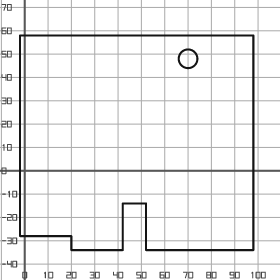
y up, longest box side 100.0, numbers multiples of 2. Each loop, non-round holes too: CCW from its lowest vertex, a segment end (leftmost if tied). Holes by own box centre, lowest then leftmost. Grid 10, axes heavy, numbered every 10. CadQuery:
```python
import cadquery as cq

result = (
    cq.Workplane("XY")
    .moveTo(20.0, -34.0)
    .lineTo(42.0, -34.0)
    .lineTo(42.0, -14.0)
    .lineTo(52.0, -14.0)
    .lineTo(52.0, -34.0)
    .lineTo(98.0, -34.0)
    .lineTo(98.0, 58.0)
    .lineTo(-2.0, 58.0)
    .lineTo(-2.0, -28.0)
    .lineTo(20.0, -28.0)
    .close()
    .moveTo(70.0, 48.0)
    .circle(4.0)
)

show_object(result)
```